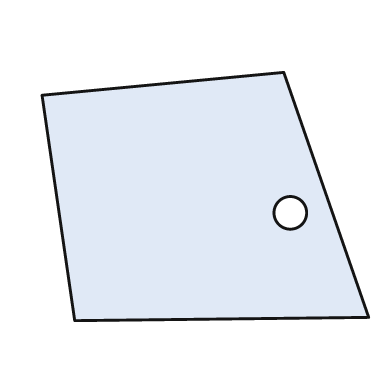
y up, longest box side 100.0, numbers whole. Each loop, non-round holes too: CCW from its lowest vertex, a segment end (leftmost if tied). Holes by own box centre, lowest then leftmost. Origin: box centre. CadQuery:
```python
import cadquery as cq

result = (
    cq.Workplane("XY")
    .moveTo(-40.0, -38.0)
    .lineTo(50.0, -37.0)
    .lineTo(24.0, 38.0)
    .lineTo(-50.0, 31.0)
    .close()
    .moveTo(26.0, -5.0)
    .circle(5.0)
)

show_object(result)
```